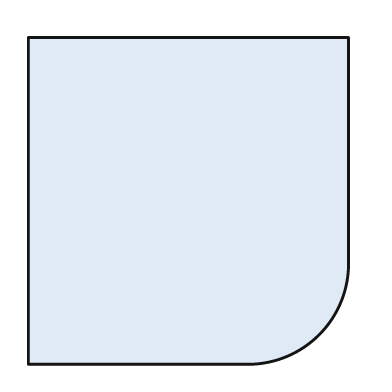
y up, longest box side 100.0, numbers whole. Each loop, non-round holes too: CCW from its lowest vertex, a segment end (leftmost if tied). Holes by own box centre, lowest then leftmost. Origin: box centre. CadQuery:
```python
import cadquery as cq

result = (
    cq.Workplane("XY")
    .moveTo(-49.0, -50.0)
    .lineTo(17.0, -50.0)
    .threePointArc((40.0, -41.0), (49.0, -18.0))
    .lineTo(49.0, 50.0)
    .lineTo(-49.0, 50.0)
    .close()
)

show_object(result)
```